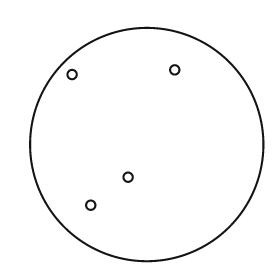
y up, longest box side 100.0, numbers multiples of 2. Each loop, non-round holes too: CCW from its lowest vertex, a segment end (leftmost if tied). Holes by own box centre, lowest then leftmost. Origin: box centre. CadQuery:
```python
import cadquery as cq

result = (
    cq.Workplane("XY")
    .moveTo(0.0, 0.0)
    .circle(50.0)
    .moveTo(-24.0, -26.0)
    .circle(2.0)
    .moveTo(-8.0, -14.0)
    .circle(2.0)
    .moveTo(-32.0, 30.0)
    .circle(2.0)
    .moveTo(12.0, 32.0)
    .circle(2.0)
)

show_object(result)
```